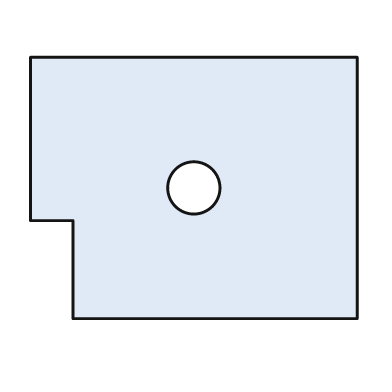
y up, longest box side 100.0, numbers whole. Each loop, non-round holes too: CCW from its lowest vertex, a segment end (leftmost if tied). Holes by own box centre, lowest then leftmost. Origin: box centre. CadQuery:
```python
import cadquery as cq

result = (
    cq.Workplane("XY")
    .moveTo(-37.0, -40.0)
    .lineTo(50.0, -40.0)
    .lineTo(50.0, 40.0)
    .lineTo(-50.0, 40.0)
    .lineTo(-50.0, -10.0)
    .lineTo(-37.0, -10.0)
    .close()
    .moveTo(0.0, 0.0)
    .circle(8.0)
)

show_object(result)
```